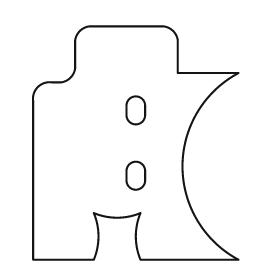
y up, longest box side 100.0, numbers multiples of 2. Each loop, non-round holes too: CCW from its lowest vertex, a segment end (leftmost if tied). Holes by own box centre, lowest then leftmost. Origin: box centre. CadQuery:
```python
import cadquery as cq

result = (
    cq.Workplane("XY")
    .moveTo(-44.0, -50.0)
    .lineTo(-18.0, -50.0)
    .threePointArc((-16.0, -40.0), (-18.0, -30.0))
    .threePointArc((-8.0, -32.0), (2.0, -30.0))
    .threePointArc((0.0, -40.0), (2.0, -50.0))
    .lineTo(44.0, -50.0)
    .threePointArc((20.0, -10.0), (44.0, 30.0))
    .lineTo(18.0, 30.0)
    .lineTo(18.0, 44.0)
    .threePointArc((16.0, 48.0), (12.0, 50.0))
    .lineTo(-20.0, 50.0)
    .threePointArc((-24.0, 48.0), (-26.0, 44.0))
    .lineTo(-26.0, 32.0)
    .threePointArc((-28.0, 28.0), (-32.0, 26.0))
    .lineTo(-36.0, 26.0)
    .threePointArc((-42.0, 24.0), (-44.0, 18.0))
    .close()
    .moveTo(-4.0, -16.0)
    .threePointArc((0.0, -20.0), (4.0, -16.0))
    .lineTo(4.0, -12.0)
    .threePointArc((0.0, -8.0), (-4.0, -12.0))
    .close()
    .moveTo(-4.0, 12.0)
    .threePointArc((0.0, 8.0), (4.0, 12.0))
    .lineTo(4.0, 16.0)
    .threePointArc((0.0, 20.0), (-4.0, 16.0))
    .close()
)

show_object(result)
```